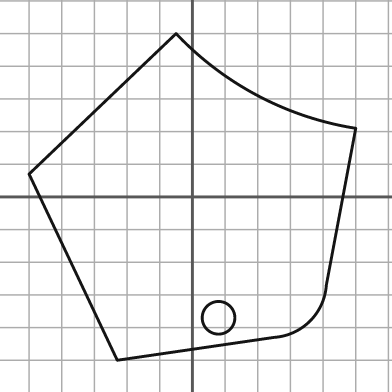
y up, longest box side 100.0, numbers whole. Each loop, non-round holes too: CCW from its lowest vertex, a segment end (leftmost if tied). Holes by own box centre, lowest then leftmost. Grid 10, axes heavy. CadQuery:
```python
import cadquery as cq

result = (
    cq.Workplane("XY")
    .moveTo(-23.0, -50.0)
    .lineTo(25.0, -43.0)
    .threePointArc((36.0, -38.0), (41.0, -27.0))
    .lineTo(50.0, 21.0)
    .threePointArc((20.0, 31.0), (-5.0, 50.0))
    .lineTo(-50.0, 7.0)
    .close()
    .moveTo(8.0, -37.0)
    .circle(5.0)
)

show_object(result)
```